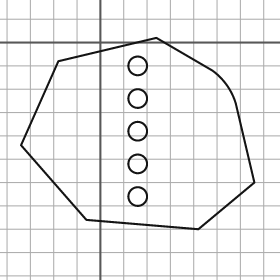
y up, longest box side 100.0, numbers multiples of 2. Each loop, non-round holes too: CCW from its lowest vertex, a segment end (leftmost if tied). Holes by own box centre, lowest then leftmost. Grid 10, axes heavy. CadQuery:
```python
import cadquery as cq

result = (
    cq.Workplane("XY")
    .moveTo(42.0, -80.0)
    .lineTo(66.0, -60.0)
    .lineTo(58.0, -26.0)
    .threePointArc((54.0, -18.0), (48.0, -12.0))
    .lineTo(24.0, 2.0)
    .lineTo(-18.0, -8.0)
    .lineTo(-34.0, -44.0)
    .lineTo(-6.0, -76.0)
    .close()
    .moveTo(16.0, -66.0)
    .circle(4.0)
    .moveTo(16.0, -52.0)
    .circle(4.0)
    .moveTo(16.0, -38.0)
    .circle(4.0)
    .moveTo(16.0, -24.0)
    .circle(4.0)
    .moveTo(16.0, -10.0)
    .circle(4.0)
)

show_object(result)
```